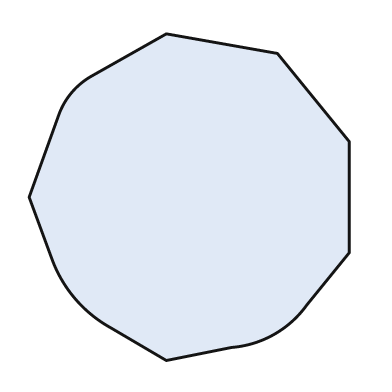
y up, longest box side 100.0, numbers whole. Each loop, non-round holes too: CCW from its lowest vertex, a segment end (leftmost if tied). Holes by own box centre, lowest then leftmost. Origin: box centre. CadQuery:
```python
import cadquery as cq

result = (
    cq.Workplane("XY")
    .moveTo(-7.0, -50.0)
    .lineTo(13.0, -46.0)
    .threePointArc((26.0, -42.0), (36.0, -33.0))
    .lineTo(49.0, -17.0)
    .lineTo(49.0, 17.0)
    .lineTo(27.0, 44.0)
    .lineTo(-7.0, 50.0)
    .lineTo(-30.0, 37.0)
    .threePointArc((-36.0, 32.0), (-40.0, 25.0))
    .lineTo(-49.0, 0.0)
    .lineTo(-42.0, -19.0)
    .threePointArc((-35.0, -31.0), (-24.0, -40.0))
    .close()
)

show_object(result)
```